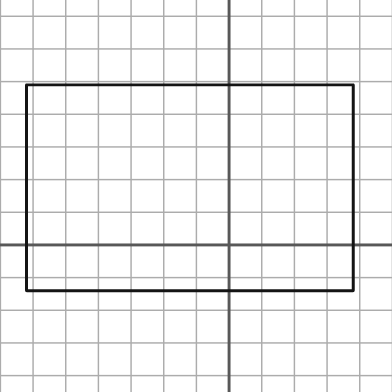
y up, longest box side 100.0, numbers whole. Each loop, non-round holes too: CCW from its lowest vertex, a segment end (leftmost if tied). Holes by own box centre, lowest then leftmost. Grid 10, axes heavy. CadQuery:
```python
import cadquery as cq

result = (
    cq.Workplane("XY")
    .moveTo(-62.0, -14.0)
    .lineTo(38.0, -14.0)
    .lineTo(38.0, 49.0)
    .lineTo(-62.0, 49.0)
    .close()
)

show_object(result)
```